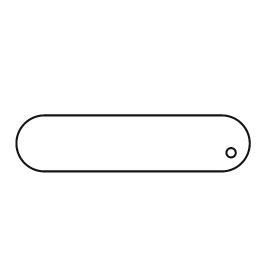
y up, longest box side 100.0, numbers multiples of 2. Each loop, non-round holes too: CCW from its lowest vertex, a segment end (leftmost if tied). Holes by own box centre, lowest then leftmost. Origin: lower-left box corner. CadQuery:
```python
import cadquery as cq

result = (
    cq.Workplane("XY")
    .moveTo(12.0, 0.0)
    .lineTo(88.0, 0.0)
    .threePointArc((100.0, 12.0), (88.0, 24.0))
    .lineTo(12.0, 24.0)
    .threePointArc((0.0, 12.0), (12.0, 0.0))
    .close()
    .moveTo(92.0, 8.0)
    .circle(2.0)
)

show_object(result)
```